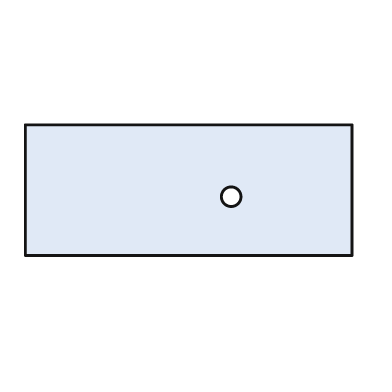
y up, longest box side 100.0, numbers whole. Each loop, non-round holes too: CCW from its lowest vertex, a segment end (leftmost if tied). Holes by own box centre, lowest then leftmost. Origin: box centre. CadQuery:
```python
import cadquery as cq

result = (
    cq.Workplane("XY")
    .moveTo(-50.0, -20.0)
    .lineTo(50.0, -20.0)
    .lineTo(50.0, 20.0)
    .lineTo(-50.0, 20.0)
    .close()
    .moveTo(13.0, -2.0)
    .circle(3.0)
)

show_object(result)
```